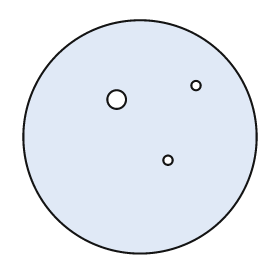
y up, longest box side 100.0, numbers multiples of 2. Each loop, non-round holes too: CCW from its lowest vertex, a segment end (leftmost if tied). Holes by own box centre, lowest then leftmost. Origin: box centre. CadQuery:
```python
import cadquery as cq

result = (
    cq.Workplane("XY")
    .moveTo(0.0, 0.0)
    .circle(50.0)
    .moveTo(12.0, -10.0)
    .circle(2.0)
    .moveTo(-10.0, 16.0)
    .circle(4.0)
    .moveTo(24.0, 22.0)
    .circle(2.0)
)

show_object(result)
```